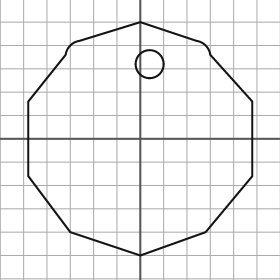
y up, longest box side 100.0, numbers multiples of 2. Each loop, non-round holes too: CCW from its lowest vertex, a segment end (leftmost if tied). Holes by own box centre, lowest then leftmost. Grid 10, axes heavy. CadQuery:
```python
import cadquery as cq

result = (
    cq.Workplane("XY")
    .moveTo(0.0, -50.0)
    .lineTo(28.0, -40.0)
    .lineTo(48.0, -16.0)
    .lineTo(48.0, 16.0)
    .lineTo(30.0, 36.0)
    .threePointArc((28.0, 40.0), (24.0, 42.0))
    .lineTo(0.0, 50.0)
    .lineTo(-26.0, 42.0)
    .threePointArc((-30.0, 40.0), (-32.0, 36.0))
    .lineTo(-48.0, 16.0)
    .lineTo(-48.0, -16.0)
    .lineTo(-30.0, -40.0)
    .close()
    .moveTo(4.0, 32.0)
    .circle(6.0)
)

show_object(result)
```